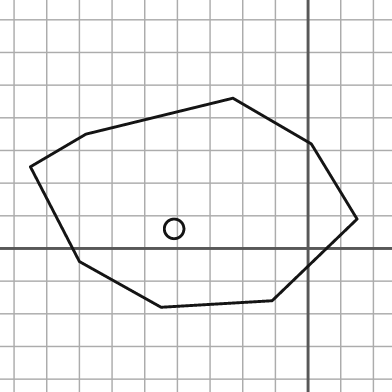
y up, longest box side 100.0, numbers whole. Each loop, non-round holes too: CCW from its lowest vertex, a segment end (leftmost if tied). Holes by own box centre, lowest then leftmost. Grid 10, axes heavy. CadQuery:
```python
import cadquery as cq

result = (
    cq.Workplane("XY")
    .moveTo(-45.0, -18.0)
    .lineTo(-11.0, -16.0)
    .lineTo(15.0, 9.0)
    .lineTo(1.0, 32.0)
    .lineTo(-23.0, 46.0)
    .lineTo(-68.0, 35.0)
    .lineTo(-85.0, 25.0)
    .lineTo(-70.0, -4.0)
    .close()
    .moveTo(-41.0, 6.0)
    .circle(3.0)
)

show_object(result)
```